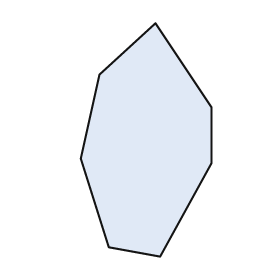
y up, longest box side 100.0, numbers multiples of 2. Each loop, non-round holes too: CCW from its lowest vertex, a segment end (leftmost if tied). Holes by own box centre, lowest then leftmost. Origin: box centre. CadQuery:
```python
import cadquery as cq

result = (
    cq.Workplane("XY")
    .moveTo(6.0, -50.0)
    .lineTo(28.0, -10.0)
    .lineTo(28.0, 14.0)
    .lineTo(4.0, 50.0)
    .lineTo(-20.0, 28.0)
    .lineTo(-28.0, -8.0)
    .lineTo(-16.0, -46.0)
    .close()
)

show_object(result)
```